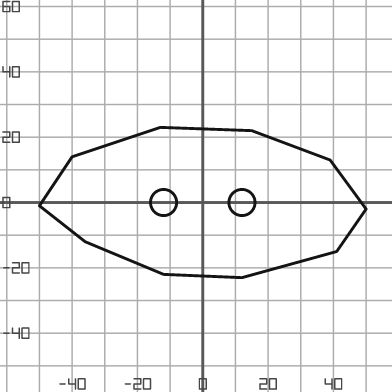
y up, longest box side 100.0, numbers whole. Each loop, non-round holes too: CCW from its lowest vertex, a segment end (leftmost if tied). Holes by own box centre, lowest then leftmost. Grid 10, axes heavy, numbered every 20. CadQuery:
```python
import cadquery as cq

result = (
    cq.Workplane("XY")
    .moveTo(12.0, -23.0)
    .lineTo(41.0, -15.0)
    .lineTo(50.0, -2.0)
    .lineTo(39.0, 13.0)
    .lineTo(15.0, 22.0)
    .lineTo(-13.0, 23.0)
    .lineTo(-40.0, 14.0)
    .lineTo(-50.0, -1.0)
    .lineTo(-36.0, -12.0)
    .lineTo(-12.0, -22.0)
    .close()
    .moveTo(-12.0, 0.0)
    .circle(4.0)
    .moveTo(12.0, 0.0)
    .circle(4.0)
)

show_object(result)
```